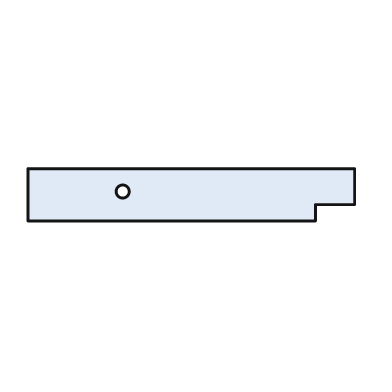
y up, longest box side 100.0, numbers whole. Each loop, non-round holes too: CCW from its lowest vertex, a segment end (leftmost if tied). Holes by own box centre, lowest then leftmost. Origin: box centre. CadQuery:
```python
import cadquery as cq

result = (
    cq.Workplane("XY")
    .moveTo(-50.0, -8.0)
    .lineTo(38.0, -8.0)
    .lineTo(38.0, -3.0)
    .lineTo(50.0, -3.0)
    .lineTo(50.0, 8.0)
    .lineTo(-50.0, 8.0)
    .close()
    .moveTo(-21.0, 1.0)
    .circle(2.0)
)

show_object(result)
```